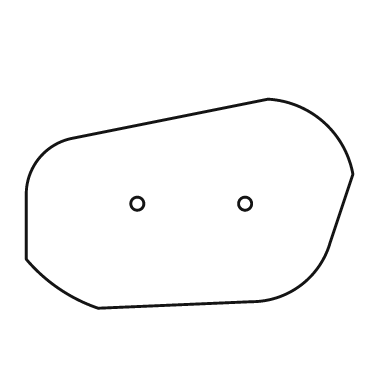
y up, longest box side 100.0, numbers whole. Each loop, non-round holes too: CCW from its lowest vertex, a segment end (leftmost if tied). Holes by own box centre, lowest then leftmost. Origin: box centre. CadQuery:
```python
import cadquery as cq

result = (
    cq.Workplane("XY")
    .moveTo(-28.0, -32.0)
    .lineTo(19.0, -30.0)
    .threePointArc((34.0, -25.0), (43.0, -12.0))
    .lineTo(50.0, 9.0)
    .threePointArc((41.0, 25.0), (24.0, 32.0))
    .lineTo(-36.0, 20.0)
    .threePointArc((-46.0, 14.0), (-50.0, 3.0))
    .lineTo(-50.0, -17.0)
    .threePointArc((-40.0, -26.0), (-28.0, -32.0))
    .close()
    .moveTo(-16.0, 0.0)
    .circle(2.0)
    .moveTo(17.0, 0.0)
    .circle(2.0)
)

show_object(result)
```